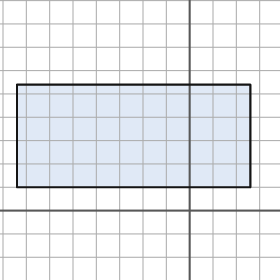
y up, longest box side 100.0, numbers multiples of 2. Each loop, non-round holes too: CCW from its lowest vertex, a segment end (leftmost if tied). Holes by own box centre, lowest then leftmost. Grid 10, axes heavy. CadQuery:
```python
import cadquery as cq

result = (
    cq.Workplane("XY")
    .moveTo(-74.0, 10.0)
    .lineTo(26.0, 10.0)
    .lineTo(26.0, 54.0)
    .lineTo(-74.0, 54.0)
    .close()
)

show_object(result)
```